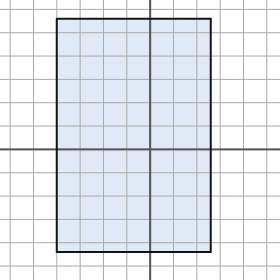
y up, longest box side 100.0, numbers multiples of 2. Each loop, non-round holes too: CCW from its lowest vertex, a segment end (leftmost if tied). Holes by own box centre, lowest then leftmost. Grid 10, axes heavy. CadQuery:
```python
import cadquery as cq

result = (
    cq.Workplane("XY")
    .moveTo(-40.0, -44.0)
    .lineTo(26.0, -44.0)
    .lineTo(26.0, 56.0)
    .lineTo(-40.0, 56.0)
    .close()
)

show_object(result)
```